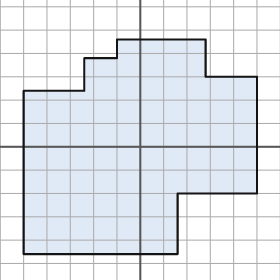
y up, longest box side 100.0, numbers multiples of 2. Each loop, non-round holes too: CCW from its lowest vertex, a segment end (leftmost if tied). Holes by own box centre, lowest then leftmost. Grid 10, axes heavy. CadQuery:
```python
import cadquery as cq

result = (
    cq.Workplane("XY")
    .moveTo(-50.0, -46.0)
    .lineTo(16.0, -46.0)
    .lineTo(16.0, -20.0)
    .lineTo(50.0, -20.0)
    .lineTo(50.0, 30.0)
    .lineTo(28.0, 30.0)
    .lineTo(28.0, 46.0)
    .lineTo(-10.0, 46.0)
    .lineTo(-10.0, 38.0)
    .lineTo(-24.0, 38.0)
    .lineTo(-24.0, 24.0)
    .lineTo(-50.0, 24.0)
    .close()
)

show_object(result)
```